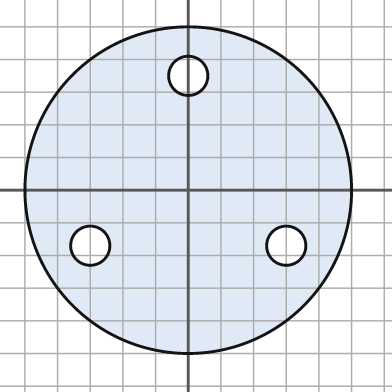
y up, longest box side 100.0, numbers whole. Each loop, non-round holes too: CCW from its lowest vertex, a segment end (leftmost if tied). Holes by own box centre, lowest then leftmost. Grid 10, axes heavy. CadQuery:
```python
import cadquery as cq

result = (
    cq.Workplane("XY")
    .moveTo(0.0, 0.0)
    .circle(50.0)
    .moveTo(-30.0, -17.0)
    .circle(6.0)
    .moveTo(30.0, -17.0)
    .circle(6.0)
    .moveTo(0.0, 35.0)
    .circle(6.0)
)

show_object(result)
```